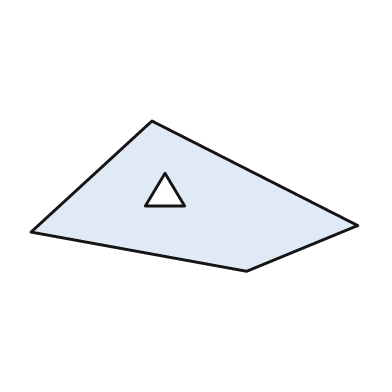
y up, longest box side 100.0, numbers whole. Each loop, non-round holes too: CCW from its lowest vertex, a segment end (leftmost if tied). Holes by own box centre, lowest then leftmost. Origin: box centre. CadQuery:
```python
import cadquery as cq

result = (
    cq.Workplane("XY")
    .moveTo(16.0, -23.0)
    .lineTo(50.0, -9.0)
    .lineTo(-13.0, 23.0)
    .lineTo(-50.0, -11.0)
    .close()
    .moveTo(-15.0, -3.0)
    .lineTo(-3.0, -3.0)
    .lineTo(-9.0, 7.0)
    .close()
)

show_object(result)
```